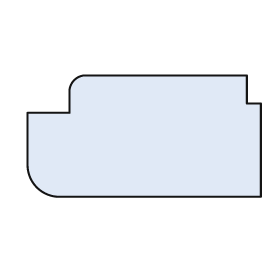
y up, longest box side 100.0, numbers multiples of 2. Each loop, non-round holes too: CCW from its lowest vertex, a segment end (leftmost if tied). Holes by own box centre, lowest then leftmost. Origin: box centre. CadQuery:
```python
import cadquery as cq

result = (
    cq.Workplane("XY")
    .moveTo(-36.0, -26.0)
    .lineTo(50.0, -26.0)
    .lineTo(50.0, 14.0)
    .lineTo(44.0, 14.0)
    .lineTo(44.0, 26.0)
    .lineTo(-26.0, 26.0)
    .threePointArc((-30.0, 24.0), (-32.0, 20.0))
    .lineTo(-32.0, 10.0)
    .lineTo(-50.0, 10.0)
    .lineTo(-50.0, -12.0)
    .threePointArc((-46.0, -22.0), (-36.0, -26.0))
    .close()
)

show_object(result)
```